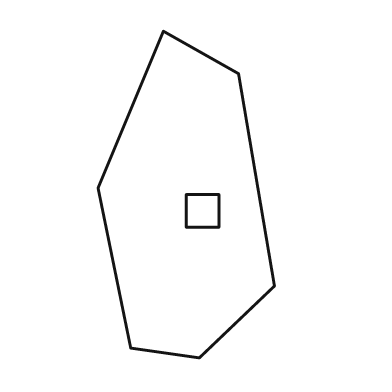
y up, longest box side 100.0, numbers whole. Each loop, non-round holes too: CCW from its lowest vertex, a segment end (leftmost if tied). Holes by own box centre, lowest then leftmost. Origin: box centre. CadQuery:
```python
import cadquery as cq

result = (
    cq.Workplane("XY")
    .moveTo(4.0, -50.0)
    .lineTo(27.0, -28.0)
    .lineTo(16.0, 37.0)
    .lineTo(-7.0, 50.0)
    .lineTo(-27.0, 2.0)
    .lineTo(-17.0, -47.0)
    .close()
    .moveTo(0.0, -10.0)
    .lineTo(10.0, -10.0)
    .lineTo(10.0, 0.0)
    .lineTo(0.0, 0.0)
    .close()
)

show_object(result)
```